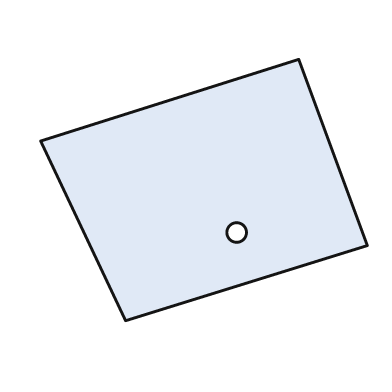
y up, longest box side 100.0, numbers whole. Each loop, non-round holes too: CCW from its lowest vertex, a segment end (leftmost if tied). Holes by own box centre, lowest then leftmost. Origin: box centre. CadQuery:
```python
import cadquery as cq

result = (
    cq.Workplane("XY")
    .moveTo(-24.0, -40.0)
    .lineTo(50.0, -17.0)
    .lineTo(29.0, 40.0)
    .lineTo(-50.0, 15.0)
    .close()
    .moveTo(10.0, -13.0)
    .circle(3.0)
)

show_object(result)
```